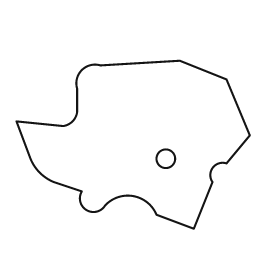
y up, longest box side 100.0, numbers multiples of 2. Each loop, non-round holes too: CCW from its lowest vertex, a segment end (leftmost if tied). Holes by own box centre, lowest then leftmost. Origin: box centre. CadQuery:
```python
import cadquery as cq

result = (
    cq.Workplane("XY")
    .moveTo(26.0, -36.0)
    .lineTo(34.0, -16.0)
    .threePointArc((34.0, -10.0), (40.0, -8.0))
    .lineTo(50.0, 4.0)
    .lineTo(40.0, 28.0)
    .lineTo(20.0, 36.0)
    .lineTo(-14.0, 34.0)
    .threePointArc((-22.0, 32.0), (-24.0, 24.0))
    .lineTo(-24.0, 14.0)
    .threePointArc((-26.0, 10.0), (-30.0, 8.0))
    .lineTo(-50.0, 10.0)
    .lineTo(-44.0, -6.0)
    .threePointArc((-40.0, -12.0), (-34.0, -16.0))
    .lineTo(-22.0, -20.0)
    .threePointArc((-20.0, -28.0), (-12.0, -26.0))
    .threePointArc((0.0, -22.0), (10.0, -30.0))
    .close()
    .moveTo(14.0, -6.0)
    .circle(4.0)
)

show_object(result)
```